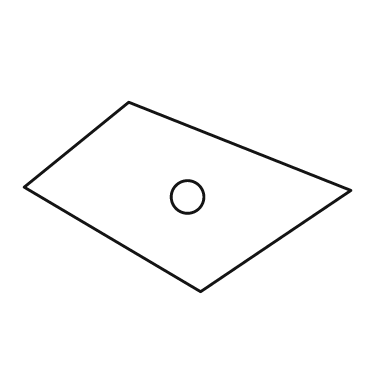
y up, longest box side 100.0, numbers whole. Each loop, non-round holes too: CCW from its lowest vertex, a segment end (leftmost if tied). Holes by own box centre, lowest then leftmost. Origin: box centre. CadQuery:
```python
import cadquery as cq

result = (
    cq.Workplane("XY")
    .moveTo(4.0, -29.0)
    .lineTo(50.0, 2.0)
    .lineTo(-18.0, 29.0)
    .lineTo(-50.0, 3.0)
    .close()
    .moveTo(0.0, 0.0)
    .circle(5.0)
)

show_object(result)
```